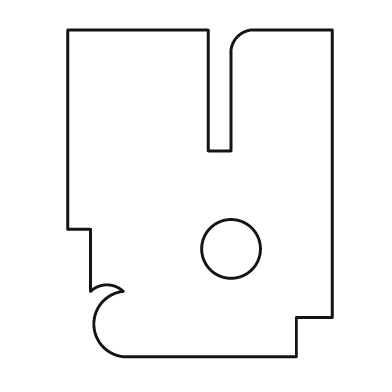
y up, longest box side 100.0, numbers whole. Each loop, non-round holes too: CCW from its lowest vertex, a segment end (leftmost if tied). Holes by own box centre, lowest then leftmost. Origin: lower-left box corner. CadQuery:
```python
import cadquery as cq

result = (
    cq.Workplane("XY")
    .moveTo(17.0, 0.0)
    .lineTo(70.0, 0.0)
    .lineTo(70.0, 12.0)
    .lineTo(81.0, 12.0)
    .lineTo(81.0, 100.0)
    .lineTo(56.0, 100.0)
    .threePointArc((52.0, 98.0), (50.0, 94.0))
    .lineTo(50.0, 63.0)
    .lineTo(43.0, 63.0)
    .lineTo(43.0, 100.0)
    .lineTo(0.0, 100.0)
    .lineTo(0.0, 39.0)
    .lineTo(7.0, 39.0)
    .lineTo(7.0, 20.0)
    .threePointArc((12.0, 22.0), (17.0, 20.0))
    .threePointArc((8.0, 10.0), (17.0, 0.0))
    .close()
    .moveTo(50.0, 33.0)
    .circle(9.0)
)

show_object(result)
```